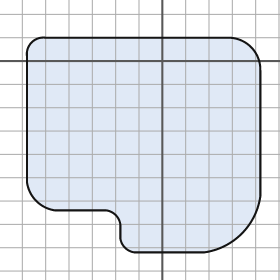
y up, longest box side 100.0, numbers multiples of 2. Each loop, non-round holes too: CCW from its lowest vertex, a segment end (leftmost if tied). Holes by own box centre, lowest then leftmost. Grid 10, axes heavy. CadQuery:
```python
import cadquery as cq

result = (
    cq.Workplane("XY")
    .moveTo(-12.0, -82.0)
    .lineTo(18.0, -82.0)
    .threePointArc((34.0, -74.0), (42.0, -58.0))
    .lineTo(42.0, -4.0)
    .threePointArc((38.0, 6.0), (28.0, 10.0))
    .lineTo(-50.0, 10.0)
    .threePointArc((-56.0, 8.0), (-58.0, 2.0))
    .lineTo(-58.0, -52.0)
    .threePointArc((-54.0, -60.0), (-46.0, -64.0))
    .lineTo(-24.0, -64.0)
    .threePointArc((-20.0, -66.0), (-18.0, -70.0))
    .lineTo(-18.0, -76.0)
    .threePointArc((-16.0, -80.0), (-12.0, -82.0))
    .close()
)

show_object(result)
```